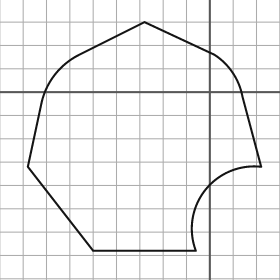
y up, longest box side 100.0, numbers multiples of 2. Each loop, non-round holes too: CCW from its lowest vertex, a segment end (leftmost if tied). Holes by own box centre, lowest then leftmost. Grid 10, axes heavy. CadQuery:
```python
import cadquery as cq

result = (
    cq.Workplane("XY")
    .moveTo(-50.0, -68.0)
    .lineTo(-6.0, -68.0)
    .threePointArc((-2.0, -42.0), (22.0, -32.0))
    .lineTo(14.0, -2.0)
    .threePointArc((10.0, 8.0), (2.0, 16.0))
    .lineTo(-28.0, 30.0)
    .lineTo(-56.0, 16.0)
    .threePointArc((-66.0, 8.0), (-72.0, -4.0))
    .lineTo(-78.0, -32.0)
    .close()
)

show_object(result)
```